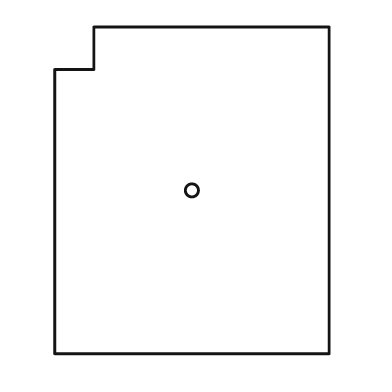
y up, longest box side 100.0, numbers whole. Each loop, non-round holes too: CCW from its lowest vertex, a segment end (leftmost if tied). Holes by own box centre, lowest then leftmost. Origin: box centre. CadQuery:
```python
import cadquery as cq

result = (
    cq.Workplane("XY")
    .moveTo(-42.0, -50.0)
    .lineTo(42.0, -50.0)
    .lineTo(42.0, 50.0)
    .lineTo(-30.0, 50.0)
    .lineTo(-30.0, 37.0)
    .lineTo(-42.0, 37.0)
    .close()
    .moveTo(0.0, 0.0)
    .circle(2.0)
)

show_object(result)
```